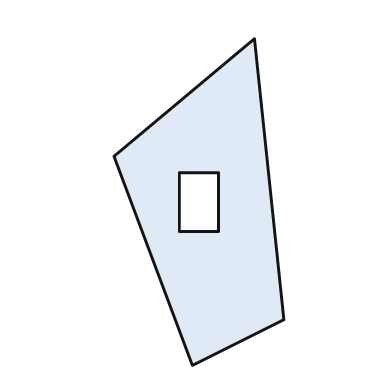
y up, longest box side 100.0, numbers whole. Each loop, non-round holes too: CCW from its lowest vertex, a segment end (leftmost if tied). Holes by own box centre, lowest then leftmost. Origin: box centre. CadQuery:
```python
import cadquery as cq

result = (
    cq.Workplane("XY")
    .moveTo(-2.0, -50.0)
    .lineTo(26.0, -36.0)
    .lineTo(17.0, 50.0)
    .lineTo(-26.0, 14.0)
    .close()
    .moveTo(-6.0, -9.0)
    .lineTo(6.0, -9.0)
    .lineTo(6.0, 9.0)
    .lineTo(-6.0, 9.0)
    .close()
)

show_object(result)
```